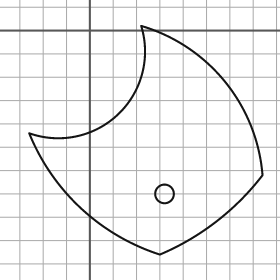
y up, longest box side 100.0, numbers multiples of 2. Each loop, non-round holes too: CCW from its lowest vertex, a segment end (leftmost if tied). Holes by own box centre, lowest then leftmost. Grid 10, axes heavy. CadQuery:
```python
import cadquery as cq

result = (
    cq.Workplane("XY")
    .moveTo(30.0, -96.0)
    .threePointArc((54.0, -82.0), (74.0, -62.0))
    .threePointArc((58.0, -22.0), (22.0, 2.0))
    .threePointArc((12.0, -36.0), (-26.0, -44.0))
    .threePointArc((-4.0, -76.0), (30.0, -96.0))
    .close()
    .moveTo(32.0, -70.0)
    .circle(4.0)
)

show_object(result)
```